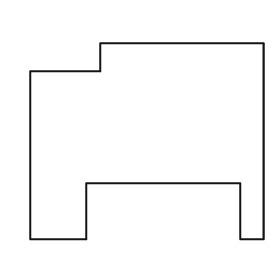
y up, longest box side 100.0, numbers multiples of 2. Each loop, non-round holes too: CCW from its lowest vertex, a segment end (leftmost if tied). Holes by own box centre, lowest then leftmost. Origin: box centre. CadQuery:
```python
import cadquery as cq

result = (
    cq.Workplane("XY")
    .moveTo(-50.0, -42.0)
    .lineTo(-26.0, -42.0)
    .lineTo(-26.0, -18.0)
    .lineTo(40.0, -18.0)
    .lineTo(40.0, -42.0)
    .lineTo(50.0, -42.0)
    .lineTo(50.0, 42.0)
    .lineTo(-20.0, 42.0)
    .lineTo(-20.0, 30.0)
    .lineTo(-50.0, 30.0)
    .close()
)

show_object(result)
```